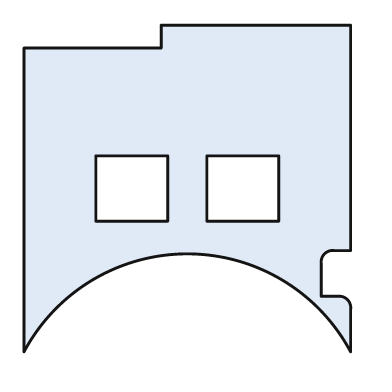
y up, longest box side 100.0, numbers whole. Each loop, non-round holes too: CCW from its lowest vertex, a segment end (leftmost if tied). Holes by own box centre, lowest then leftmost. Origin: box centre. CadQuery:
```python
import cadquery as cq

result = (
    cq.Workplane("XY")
    .moveTo(-50.0, -50.0)
    .threePointArc((0.0, -20.0), (50.0, -50.0))
    .lineTo(50.0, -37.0)
    .threePointArc((49.0, -34.0), (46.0, -33.0))
    .lineTo(41.0, -33.0)
    .lineTo(41.0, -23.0)
    .threePointArc((42.0, -20.0), (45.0, -19.0))
    .lineTo(50.0, -19.0)
    .lineTo(50.0, 50.0)
    .lineTo(-8.0, 50.0)
    .lineTo(-8.0, 43.0)
    .lineTo(-50.0, 43.0)
    .close()
    .moveTo(-28.0, -10.0)
    .lineTo(-6.0, -10.0)
    .lineTo(-6.0, 10.0)
    .lineTo(-28.0, 10.0)
    .close()
    .moveTo(6.0, -10.0)
    .lineTo(28.0, -10.0)
    .lineTo(28.0, 10.0)
    .lineTo(6.0, 10.0)
    .close()
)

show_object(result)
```